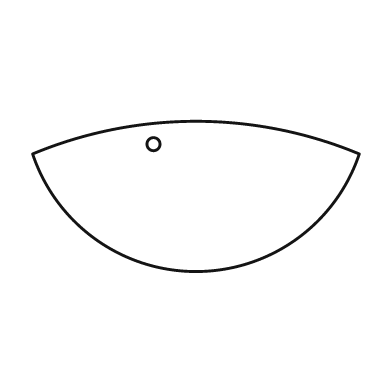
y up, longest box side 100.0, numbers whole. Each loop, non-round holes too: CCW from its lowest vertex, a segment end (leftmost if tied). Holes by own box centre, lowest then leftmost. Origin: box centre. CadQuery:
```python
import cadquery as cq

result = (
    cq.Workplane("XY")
    .moveTo(-50.0, 13.0)
    .threePointArc((0.0, -23.0), (50.0, 13.0))
    .threePointArc((0.0, 23.0), (-50.0, 13.0))
    .close()
    .moveTo(-13.0, 16.0)
    .circle(2.0)
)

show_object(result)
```